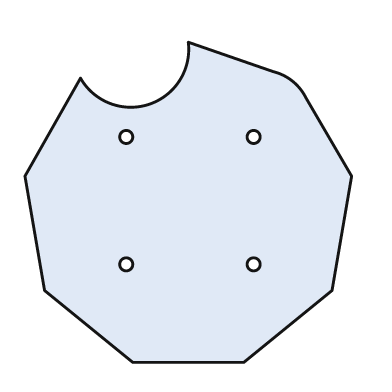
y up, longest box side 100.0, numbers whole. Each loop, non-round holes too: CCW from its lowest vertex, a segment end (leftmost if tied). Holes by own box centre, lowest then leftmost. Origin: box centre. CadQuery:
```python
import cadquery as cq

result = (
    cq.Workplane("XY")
    .moveTo(-17.0, -49.0)
    .lineTo(17.0, -49.0)
    .lineTo(44.0, -27.0)
    .lineTo(50.0, 8.0)
    .lineTo(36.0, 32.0)
    .threePointArc((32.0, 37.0), (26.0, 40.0))
    .lineTo(0.0, 49.0)
    .threePointArc((-12.0, 30.0), (-33.0, 38.0))
    .lineTo(-50.0, 8.0)
    .lineTo(-44.0, -27.0)
    .close()
    .moveTo(-19.0, -19.0)
    .circle(2.0)
    .moveTo(20.0, -19.0)
    .circle(2.0)
    .moveTo(-19.0, 20.0)
    .circle(2.0)
    .moveTo(20.0, 20.0)
    .circle(2.0)
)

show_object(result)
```